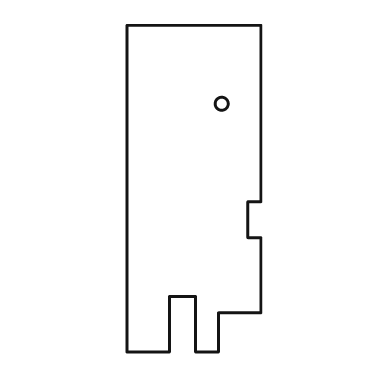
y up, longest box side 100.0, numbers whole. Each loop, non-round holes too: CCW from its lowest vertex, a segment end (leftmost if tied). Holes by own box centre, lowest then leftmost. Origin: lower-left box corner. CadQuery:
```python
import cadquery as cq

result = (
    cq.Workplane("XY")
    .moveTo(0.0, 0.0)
    .lineTo(13.0, 0.0)
    .lineTo(13.0, 17.0)
    .lineTo(21.0, 17.0)
    .lineTo(21.0, 0.0)
    .lineTo(28.0, 0.0)
    .lineTo(28.0, 12.0)
    .lineTo(41.0, 12.0)
    .lineTo(41.0, 35.0)
    .lineTo(37.0, 35.0)
    .lineTo(37.0, 46.0)
    .lineTo(41.0, 46.0)
    .lineTo(41.0, 100.0)
    .lineTo(0.0, 100.0)
    .close()
    .moveTo(29.0, 76.0)
    .circle(2.0)
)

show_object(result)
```